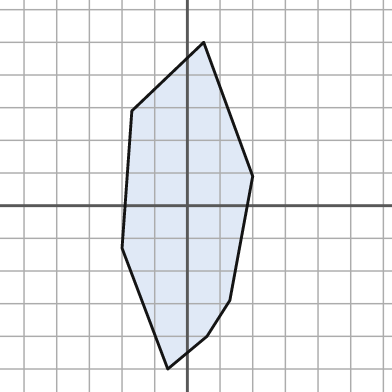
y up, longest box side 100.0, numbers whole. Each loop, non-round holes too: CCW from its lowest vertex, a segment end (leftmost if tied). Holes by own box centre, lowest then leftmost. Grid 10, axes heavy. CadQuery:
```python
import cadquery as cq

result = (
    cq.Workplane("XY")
    .moveTo(-6.0, -50.0)
    .lineTo(6.0, -40.0)
    .lineTo(13.0, -29.0)
    .lineTo(20.0, 9.0)
    .lineTo(5.0, 50.0)
    .lineTo(-17.0, 29.0)
    .lineTo(-20.0, -13.0)
    .close()
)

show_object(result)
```